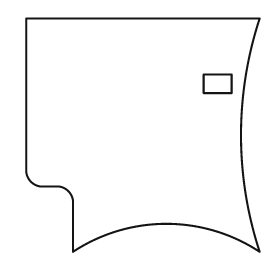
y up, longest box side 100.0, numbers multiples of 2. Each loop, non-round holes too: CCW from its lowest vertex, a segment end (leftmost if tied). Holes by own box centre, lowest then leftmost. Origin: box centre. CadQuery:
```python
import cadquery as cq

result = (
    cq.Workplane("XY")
    .moveTo(-30.0, -50.0)
    .threePointArc((10.0, -38.0), (50.0, -50.0))
    .threePointArc((42.0, 0.0), (50.0, 50.0))
    .lineTo(-50.0, 50.0)
    .lineTo(-50.0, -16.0)
    .threePointArc((-48.0, -20.0), (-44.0, -22.0))
    .lineTo(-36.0, -22.0)
    .threePointArc((-32.0, -24.0), (-30.0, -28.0))
    .close()
    .moveTo(26.0, 18.0)
    .lineTo(38.0, 18.0)
    .lineTo(38.0, 26.0)
    .lineTo(26.0, 26.0)
    .close()
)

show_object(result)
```